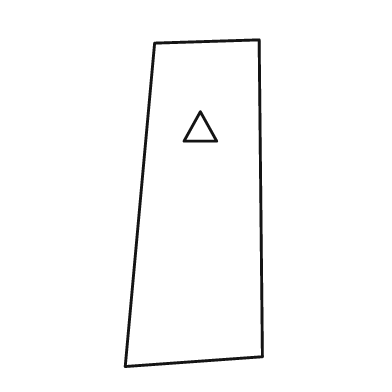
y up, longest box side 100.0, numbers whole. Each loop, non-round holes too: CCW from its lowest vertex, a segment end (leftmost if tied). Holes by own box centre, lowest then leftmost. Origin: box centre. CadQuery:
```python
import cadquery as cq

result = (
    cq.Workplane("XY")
    .moveTo(-21.0, -50.0)
    .lineTo(21.0, -47.0)
    .lineTo(20.0, 50.0)
    .lineTo(-12.0, 49.0)
    .close()
    .moveTo(-3.0, 19.0)
    .lineTo(7.0, 19.0)
    .lineTo(2.0, 28.0)
    .close()
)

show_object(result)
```